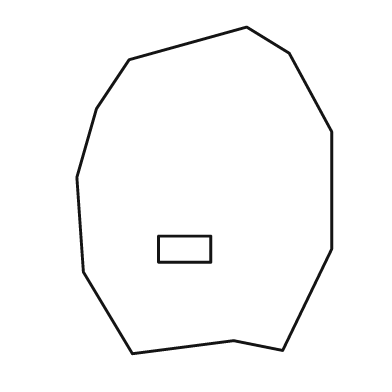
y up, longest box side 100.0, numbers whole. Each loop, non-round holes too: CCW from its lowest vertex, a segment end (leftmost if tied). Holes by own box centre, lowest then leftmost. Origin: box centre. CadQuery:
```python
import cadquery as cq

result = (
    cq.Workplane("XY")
    .moveTo(-22.0, -50.0)
    .lineTo(9.0, -46.0)
    .lineTo(24.0, -49.0)
    .lineTo(39.0, -18.0)
    .lineTo(39.0, 18.0)
    .lineTo(26.0, 42.0)
    .lineTo(13.0, 50.0)
    .lineTo(-23.0, 40.0)
    .lineTo(-33.0, 25.0)
    .lineTo(-39.0, 4.0)
    .lineTo(-37.0, -25.0)
    .close()
    .moveTo(-14.0, -22.0)
    .lineTo(2.0, -22.0)
    .lineTo(2.0, -14.0)
    .lineTo(-14.0, -14.0)
    .close()
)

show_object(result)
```